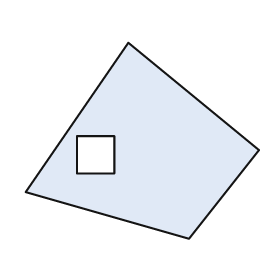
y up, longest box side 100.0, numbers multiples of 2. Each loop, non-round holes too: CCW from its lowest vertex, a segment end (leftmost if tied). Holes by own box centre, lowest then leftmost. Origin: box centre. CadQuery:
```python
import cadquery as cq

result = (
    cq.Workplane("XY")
    .moveTo(20.0, -42.0)
    .lineTo(50.0, -4.0)
    .lineTo(-6.0, 42.0)
    .lineTo(-50.0, -22.0)
    .close()
    .moveTo(-28.0, -14.0)
    .lineTo(-12.0, -14.0)
    .lineTo(-12.0, 2.0)
    .lineTo(-28.0, 2.0)
    .close()
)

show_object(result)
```